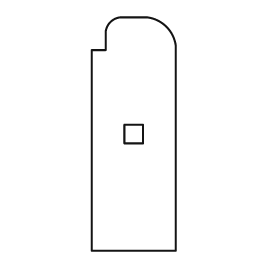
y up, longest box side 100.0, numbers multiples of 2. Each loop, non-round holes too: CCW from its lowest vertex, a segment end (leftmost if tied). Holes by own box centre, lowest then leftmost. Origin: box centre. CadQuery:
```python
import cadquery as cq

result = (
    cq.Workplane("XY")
    .moveTo(-18.0, -50.0)
    .lineTo(18.0, -50.0)
    .lineTo(18.0, 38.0)
    .threePointArc((14.0, 46.0), (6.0, 50.0))
    .lineTo(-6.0, 50.0)
    .threePointArc((-10.0, 48.0), (-12.0, 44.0))
    .lineTo(-12.0, 36.0)
    .lineTo(-18.0, 36.0)
    .close()
    .moveTo(-4.0, -4.0)
    .lineTo(4.0, -4.0)
    .lineTo(4.0, 4.0)
    .lineTo(-4.0, 4.0)
    .close()
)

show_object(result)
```